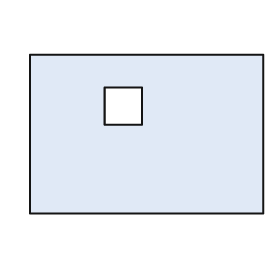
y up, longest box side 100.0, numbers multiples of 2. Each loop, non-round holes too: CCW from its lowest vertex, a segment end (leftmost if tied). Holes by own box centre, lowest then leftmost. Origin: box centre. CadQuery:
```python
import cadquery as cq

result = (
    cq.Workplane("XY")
    .moveTo(-50.0, -34.0)
    .lineTo(50.0, -34.0)
    .lineTo(50.0, 34.0)
    .lineTo(-50.0, 34.0)
    .close()
    .moveTo(-18.0, 4.0)
    .lineTo(-2.0, 4.0)
    .lineTo(-2.0, 20.0)
    .lineTo(-18.0, 20.0)
    .close()
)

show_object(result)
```